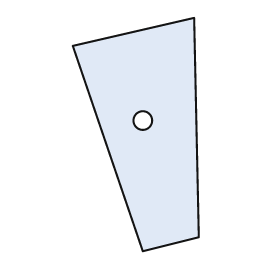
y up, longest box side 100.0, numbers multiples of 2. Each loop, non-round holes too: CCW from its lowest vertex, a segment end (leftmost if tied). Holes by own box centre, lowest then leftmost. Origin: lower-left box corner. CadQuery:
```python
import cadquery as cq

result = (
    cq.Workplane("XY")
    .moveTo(30.0, 0.0)
    .lineTo(54.0, 6.0)
    .lineTo(52.0, 100.0)
    .lineTo(0.0, 88.0)
    .close()
    .moveTo(30.0, 56.0)
    .circle(4.0)
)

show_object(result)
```